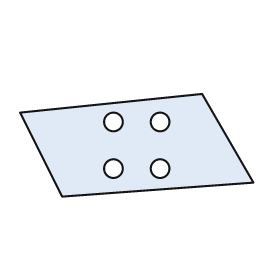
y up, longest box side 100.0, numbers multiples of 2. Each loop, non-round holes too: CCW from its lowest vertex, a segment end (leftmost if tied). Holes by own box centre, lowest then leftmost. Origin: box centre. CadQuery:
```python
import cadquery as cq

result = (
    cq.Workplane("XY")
    .moveTo(-32.0, -22.0)
    .lineTo(50.0, -16.0)
    .lineTo(28.0, 22.0)
    .lineTo(-50.0, 14.0)
    .close()
    .moveTo(-10.0, -10.0)
    .circle(4.0)
    .moveTo(10.0, -10.0)
    .circle(4.0)
    .moveTo(-10.0, 10.0)
    .circle(4.0)
    .moveTo(10.0, 10.0)
    .circle(4.0)
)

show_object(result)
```